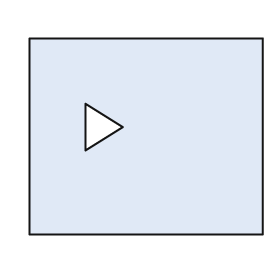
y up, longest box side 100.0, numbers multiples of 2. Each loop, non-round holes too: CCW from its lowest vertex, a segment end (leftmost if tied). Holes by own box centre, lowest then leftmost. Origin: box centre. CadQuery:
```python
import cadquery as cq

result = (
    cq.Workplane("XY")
    .moveTo(-50.0, -42.0)
    .lineTo(50.0, -42.0)
    .lineTo(50.0, 42.0)
    .lineTo(-50.0, 42.0)
    .close()
    .moveTo(-26.0, -6.0)
    .lineTo(-10.0, 4.0)
    .lineTo(-26.0, 14.0)
    .close()
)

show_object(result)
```